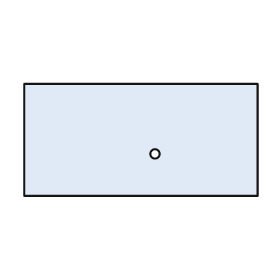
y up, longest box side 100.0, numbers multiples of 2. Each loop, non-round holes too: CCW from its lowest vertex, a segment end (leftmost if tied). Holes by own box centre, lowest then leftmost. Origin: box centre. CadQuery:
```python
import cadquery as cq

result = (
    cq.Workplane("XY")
    .moveTo(-50.0, -24.0)
    .lineTo(50.0, -24.0)
    .lineTo(50.0, 24.0)
    .lineTo(-50.0, 24.0)
    .close()
    .moveTo(6.0, -6.0)
    .circle(2.0)
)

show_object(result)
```